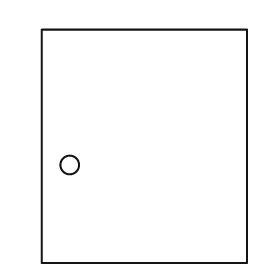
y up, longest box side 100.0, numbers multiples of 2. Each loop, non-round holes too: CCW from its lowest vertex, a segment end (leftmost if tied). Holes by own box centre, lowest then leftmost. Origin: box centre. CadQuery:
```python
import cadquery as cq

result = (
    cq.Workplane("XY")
    .moveTo(-44.0, -50.0)
    .lineTo(44.0, -50.0)
    .lineTo(44.0, 50.0)
    .lineTo(-44.0, 50.0)
    .close()
    .moveTo(-32.0, -8.0)
    .circle(4.0)
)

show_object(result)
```